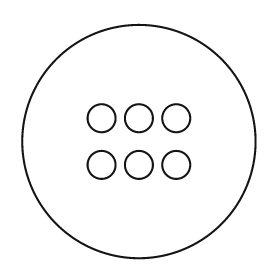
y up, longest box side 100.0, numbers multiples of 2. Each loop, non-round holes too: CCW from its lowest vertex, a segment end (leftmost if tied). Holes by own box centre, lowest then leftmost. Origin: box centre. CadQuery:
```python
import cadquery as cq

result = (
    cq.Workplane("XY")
    .moveTo(0.0, 0.0)
    .circle(50.0)
    .moveTo(-16.0, -10.0)
    .circle(6.0)
    .moveTo(0.0, -10.0)
    .circle(6.0)
    .moveTo(16.0, -10.0)
    .circle(6.0)
    .moveTo(-16.0, 10.0)
    .circle(6.0)
    .moveTo(0.0, 10.0)
    .circle(6.0)
    .moveTo(16.0, 10.0)
    .circle(6.0)
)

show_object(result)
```